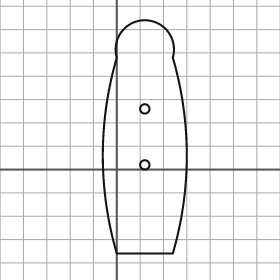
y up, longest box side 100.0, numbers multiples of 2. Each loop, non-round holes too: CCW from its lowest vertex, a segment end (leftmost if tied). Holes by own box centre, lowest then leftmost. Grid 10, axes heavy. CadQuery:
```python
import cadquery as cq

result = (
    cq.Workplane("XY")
    .moveTo(0.0, -36.0)
    .lineTo(24.0, -36.0)
    .threePointArc((30.0, 6.0), (24.0, 48.0))
    .threePointArc((12.0, 64.0), (0.0, 48.0))
    .threePointArc((-6.0, 6.0), (0.0, -36.0))
    .close()
    .moveTo(12.0, 2.0)
    .circle(2.0)
    .moveTo(12.0, 26.0)
    .circle(2.0)
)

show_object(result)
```